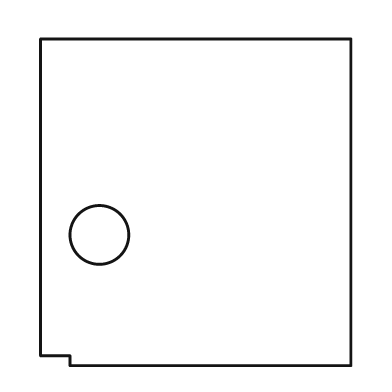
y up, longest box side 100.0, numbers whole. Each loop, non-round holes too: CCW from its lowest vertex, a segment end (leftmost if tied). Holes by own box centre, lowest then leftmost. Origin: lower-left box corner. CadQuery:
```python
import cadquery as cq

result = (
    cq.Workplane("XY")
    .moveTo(9.0, 0.0)
    .lineTo(95.0, 0.0)
    .lineTo(95.0, 100.0)
    .lineTo(0.0, 100.0)
    .lineTo(0.0, 3.0)
    .lineTo(9.0, 3.0)
    .close()
    .moveTo(18.0, 40.0)
    .circle(9.0)
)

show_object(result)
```